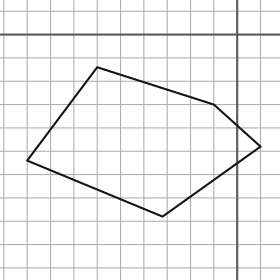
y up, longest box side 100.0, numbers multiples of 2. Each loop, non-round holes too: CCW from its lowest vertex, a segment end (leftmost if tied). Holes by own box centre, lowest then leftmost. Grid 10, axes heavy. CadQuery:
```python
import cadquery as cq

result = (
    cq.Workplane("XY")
    .moveTo(-32.0, -78.0)
    .lineTo(10.0, -48.0)
    .lineTo(-10.0, -30.0)
    .lineTo(-60.0, -14.0)
    .lineTo(-90.0, -54.0)
    .close()
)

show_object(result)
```